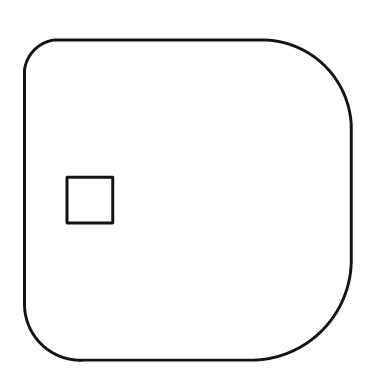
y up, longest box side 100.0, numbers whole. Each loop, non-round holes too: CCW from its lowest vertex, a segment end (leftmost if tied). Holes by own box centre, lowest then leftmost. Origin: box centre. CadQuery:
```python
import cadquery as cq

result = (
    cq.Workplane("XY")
    .moveTo(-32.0, -49.0)
    .lineTo(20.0, -49.0)
    .threePointArc((41.0, -40.0), (50.0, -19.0))
    .lineTo(50.0, 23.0)
    .threePointArc((42.0, 41.0), (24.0, 49.0))
    .lineTo(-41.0, 49.0)
    .threePointArc((-47.0, 46.0), (-50.0, 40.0))
    .lineTo(-50.0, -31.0)
    .threePointArc((-45.0, -44.0), (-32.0, -49.0))
    .close()
    .moveTo(-37.0, -7.0)
    .lineTo(-23.0, -7.0)
    .lineTo(-23.0, 7.0)
    .lineTo(-37.0, 7.0)
    .close()
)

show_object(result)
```